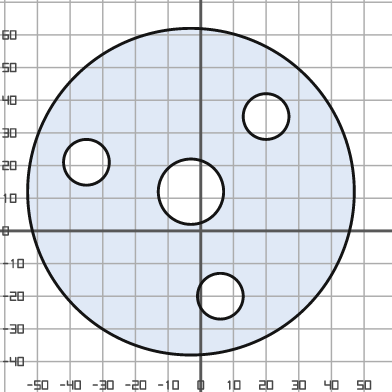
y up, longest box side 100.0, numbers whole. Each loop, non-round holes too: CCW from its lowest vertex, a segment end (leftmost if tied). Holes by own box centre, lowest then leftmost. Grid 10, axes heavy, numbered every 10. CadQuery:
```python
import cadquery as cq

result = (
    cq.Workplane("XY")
    .moveTo(-3.0, 12.0)
    .circle(50.0)
    .moveTo(6.0, -20.0)
    .circle(7.0)
    .moveTo(-3.0, 12.0)
    .circle(10.0)
    .moveTo(-35.0, 21.0)
    .circle(7.0)
    .moveTo(20.0, 35.0)
    .circle(7.0)
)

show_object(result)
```